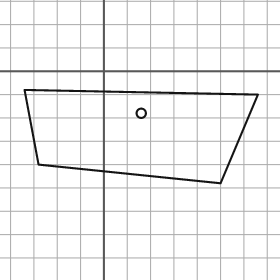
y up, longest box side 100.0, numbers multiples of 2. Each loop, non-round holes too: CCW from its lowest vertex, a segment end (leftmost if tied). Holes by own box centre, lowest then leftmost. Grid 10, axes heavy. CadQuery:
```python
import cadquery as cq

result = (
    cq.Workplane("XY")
    .moveTo(50.0, -48.0)
    .lineTo(66.0, -10.0)
    .lineTo(-34.0, -8.0)
    .lineTo(-28.0, -40.0)
    .close()
    .moveTo(16.0, -18.0)
    .circle(2.0)
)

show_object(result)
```